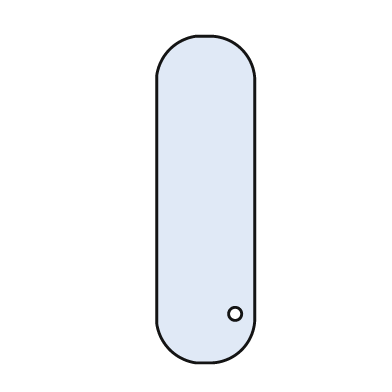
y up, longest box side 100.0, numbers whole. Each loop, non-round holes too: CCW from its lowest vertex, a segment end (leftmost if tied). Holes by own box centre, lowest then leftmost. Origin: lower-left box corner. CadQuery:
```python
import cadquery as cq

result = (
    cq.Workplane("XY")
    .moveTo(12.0, 0.0)
    .lineTo(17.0, 0.0)
    .threePointArc((26.0, 4.0), (30.0, 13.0))
    .lineTo(30.0, 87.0)
    .threePointArc((26.0, 96.0), (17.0, 100.0))
    .lineTo(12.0, 100.0)
    .threePointArc((4.0, 96.0), (0.0, 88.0))
    .lineTo(0.0, 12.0)
    .threePointArc((4.0, 4.0), (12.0, 0.0))
    .close()
    .moveTo(24.0, 15.0)
    .circle(2.0)
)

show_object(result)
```